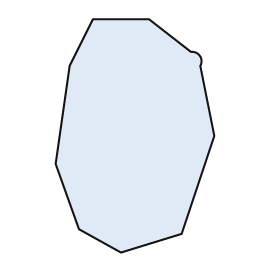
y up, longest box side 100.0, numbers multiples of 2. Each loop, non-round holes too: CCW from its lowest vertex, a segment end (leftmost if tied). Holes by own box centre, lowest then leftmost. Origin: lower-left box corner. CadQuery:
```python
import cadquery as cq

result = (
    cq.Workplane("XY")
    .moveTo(28.0, 0.0)
    .lineTo(54.0, 8.0)
    .lineTo(68.0, 50.0)
    .lineTo(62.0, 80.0)
    .threePointArc((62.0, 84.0), (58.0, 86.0))
    .lineTo(40.0, 100.0)
    .lineTo(16.0, 100.0)
    .lineTo(6.0, 80.0)
    .lineTo(0.0, 38.0)
    .lineTo(10.0, 10.0)
    .close()
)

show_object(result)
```